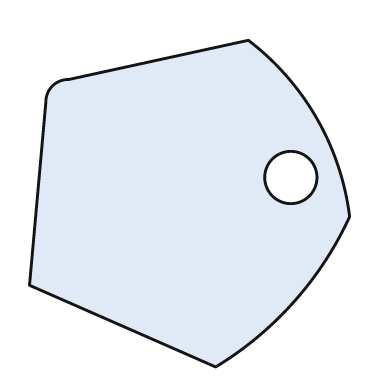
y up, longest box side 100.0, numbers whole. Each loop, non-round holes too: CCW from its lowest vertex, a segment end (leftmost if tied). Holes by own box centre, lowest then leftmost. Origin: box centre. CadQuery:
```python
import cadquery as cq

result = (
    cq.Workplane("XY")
    .moveTo(8.0, -50.0)
    .threePointArc((32.0, -30.0), (49.0, -4.0))
    .threePointArc((39.0, 26.0), (18.0, 50.0))
    .lineTo(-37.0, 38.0)
    .threePointArc((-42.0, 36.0), (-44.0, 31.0))
    .lineTo(-49.0, -25.0)
    .close()
    .moveTo(31.0, 8.0)
    .circle(8.0)
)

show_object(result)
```